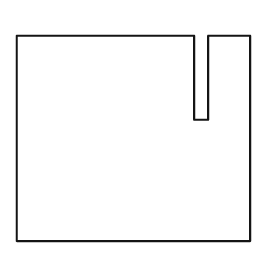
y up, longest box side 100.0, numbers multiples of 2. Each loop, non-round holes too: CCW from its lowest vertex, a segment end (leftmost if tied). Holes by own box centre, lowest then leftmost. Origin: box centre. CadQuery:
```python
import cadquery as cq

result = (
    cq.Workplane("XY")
    .moveTo(-50.0, -44.0)
    .lineTo(50.0, -44.0)
    .lineTo(50.0, 44.0)
    .lineTo(32.0, 44.0)
    .lineTo(32.0, 8.0)
    .lineTo(26.0, 8.0)
    .lineTo(26.0, 44.0)
    .lineTo(-50.0, 44.0)
    .close()
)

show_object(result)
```